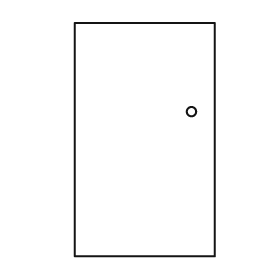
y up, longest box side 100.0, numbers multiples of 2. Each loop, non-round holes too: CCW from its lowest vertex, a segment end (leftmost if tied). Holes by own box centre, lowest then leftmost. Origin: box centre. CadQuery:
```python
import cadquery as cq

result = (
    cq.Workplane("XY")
    .moveTo(-30.0, -50.0)
    .lineTo(30.0, -50.0)
    .lineTo(30.0, 50.0)
    .lineTo(-30.0, 50.0)
    .close()
    .moveTo(20.0, 12.0)
    .circle(2.0)
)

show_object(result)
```